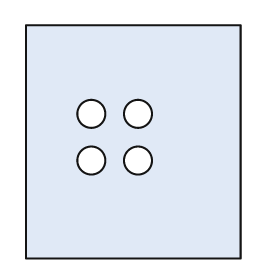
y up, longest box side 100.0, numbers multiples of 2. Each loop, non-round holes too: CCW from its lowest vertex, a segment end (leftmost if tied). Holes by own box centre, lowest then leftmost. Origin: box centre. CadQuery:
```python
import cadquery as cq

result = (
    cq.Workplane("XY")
    .moveTo(-46.0, -50.0)
    .lineTo(46.0, -50.0)
    .lineTo(46.0, 50.0)
    .lineTo(-46.0, 50.0)
    .close()
    .moveTo(-18.0, -8.0)
    .circle(6.0)
    .moveTo(2.0, -8.0)
    .circle(6.0)
    .moveTo(-18.0, 12.0)
    .circle(6.0)
    .moveTo(2.0, 12.0)
    .circle(6.0)
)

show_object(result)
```